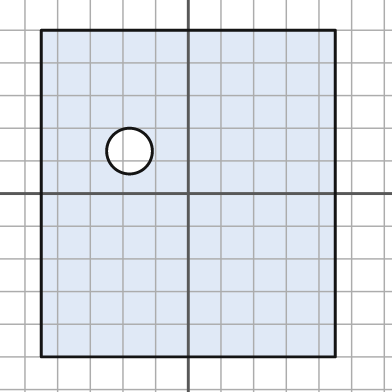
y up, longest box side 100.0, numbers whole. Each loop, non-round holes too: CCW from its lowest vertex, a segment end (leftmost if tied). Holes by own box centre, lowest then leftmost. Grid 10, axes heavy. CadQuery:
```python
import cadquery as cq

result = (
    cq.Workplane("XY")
    .moveTo(-45.0, -50.0)
    .lineTo(45.0, -50.0)
    .lineTo(45.0, 50.0)
    .lineTo(-45.0, 50.0)
    .close()
    .moveTo(-18.0, 13.0)
    .circle(7.0)
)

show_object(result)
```